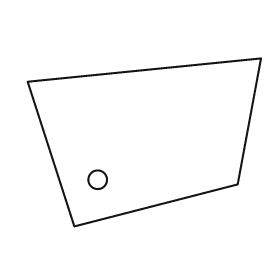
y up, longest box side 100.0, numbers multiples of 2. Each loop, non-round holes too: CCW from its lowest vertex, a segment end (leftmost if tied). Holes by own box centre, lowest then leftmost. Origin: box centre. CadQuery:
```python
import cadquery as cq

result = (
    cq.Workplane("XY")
    .moveTo(-30.0, -36.0)
    .lineTo(40.0, -18.0)
    .lineTo(50.0, 36.0)
    .lineTo(-50.0, 26.0)
    .close()
    .moveTo(-20.0, -16.0)
    .circle(4.0)
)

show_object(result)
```